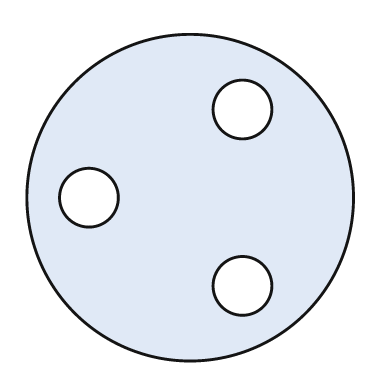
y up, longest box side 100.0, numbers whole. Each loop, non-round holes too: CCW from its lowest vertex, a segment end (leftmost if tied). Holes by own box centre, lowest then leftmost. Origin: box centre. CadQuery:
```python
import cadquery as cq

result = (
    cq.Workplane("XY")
    .moveTo(0.0, 0.0)
    .circle(50.0)
    .moveTo(16.0, -27.0)
    .circle(9.0)
    .moveTo(-31.0, 0.0)
    .circle(9.0)
    .moveTo(16.0, 27.0)
    .circle(9.0)
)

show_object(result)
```